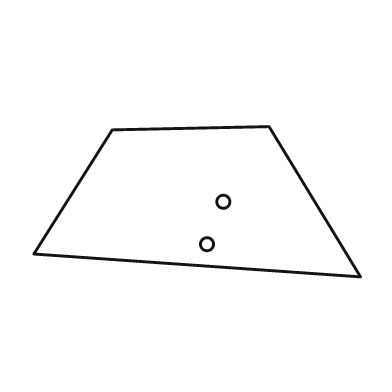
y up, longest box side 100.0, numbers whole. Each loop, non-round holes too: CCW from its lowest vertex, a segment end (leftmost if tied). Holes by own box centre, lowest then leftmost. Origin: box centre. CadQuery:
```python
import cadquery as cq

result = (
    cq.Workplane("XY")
    .moveTo(50.0, -23.0)
    .lineTo(22.0, 23.0)
    .lineTo(-26.0, 22.0)
    .lineTo(-50.0, -16.0)
    .close()
    .moveTo(3.0, -13.0)
    .circle(2.0)
    .moveTo(8.0, 0.0)
    .circle(2.0)
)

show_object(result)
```